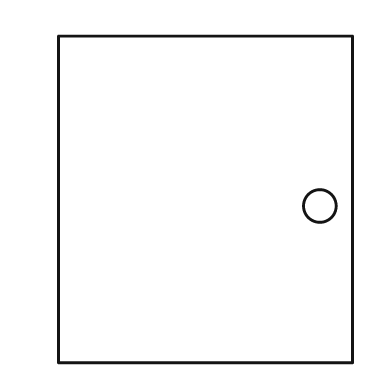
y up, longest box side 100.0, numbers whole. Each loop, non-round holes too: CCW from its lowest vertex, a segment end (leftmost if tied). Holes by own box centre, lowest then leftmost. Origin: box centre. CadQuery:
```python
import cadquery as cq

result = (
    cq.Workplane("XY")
    .moveTo(-45.0, -50.0)
    .lineTo(45.0, -50.0)
    .lineTo(45.0, 50.0)
    .lineTo(-45.0, 50.0)
    .close()
    .moveTo(35.0, -2.0)
    .circle(5.0)
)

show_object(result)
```